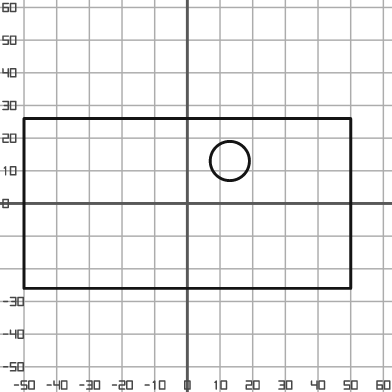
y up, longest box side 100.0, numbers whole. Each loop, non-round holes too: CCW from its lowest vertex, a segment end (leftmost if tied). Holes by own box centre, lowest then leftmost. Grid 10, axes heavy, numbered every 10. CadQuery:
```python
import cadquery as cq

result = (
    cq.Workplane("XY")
    .moveTo(-50.0, -26.0)
    .lineTo(50.0, -26.0)
    .lineTo(50.0, 26.0)
    .lineTo(-50.0, 26.0)
    .close()
    .moveTo(13.0, 13.0)
    .circle(6.0)
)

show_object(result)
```